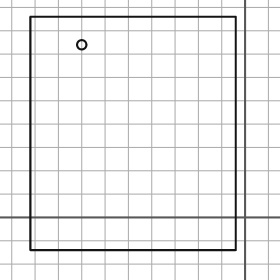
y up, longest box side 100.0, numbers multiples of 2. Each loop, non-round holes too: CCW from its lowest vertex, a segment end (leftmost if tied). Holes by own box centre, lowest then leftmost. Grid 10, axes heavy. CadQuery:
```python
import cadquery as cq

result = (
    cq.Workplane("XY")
    .moveTo(-92.0, -14.0)
    .lineTo(-4.0, -14.0)
    .lineTo(-4.0, 86.0)
    .lineTo(-92.0, 86.0)
    .close()
    .moveTo(-70.0, 74.0)
    .circle(2.0)
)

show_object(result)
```